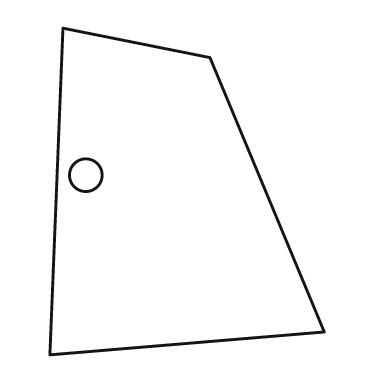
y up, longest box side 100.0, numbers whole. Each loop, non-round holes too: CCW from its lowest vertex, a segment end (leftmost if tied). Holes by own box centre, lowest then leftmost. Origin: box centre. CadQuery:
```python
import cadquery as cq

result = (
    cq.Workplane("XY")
    .moveTo(-42.0, -50.0)
    .lineTo(42.0, -43.0)
    .lineTo(7.0, 41.0)
    .lineTo(-38.0, 50.0)
    .close()
    .moveTo(-31.0, 5.0)
    .circle(5.0)
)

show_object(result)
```